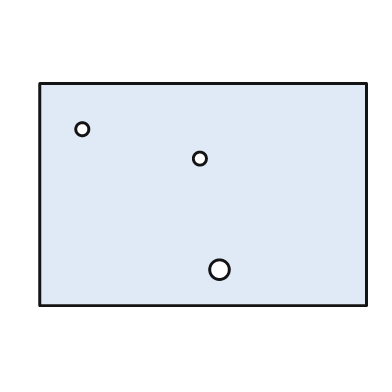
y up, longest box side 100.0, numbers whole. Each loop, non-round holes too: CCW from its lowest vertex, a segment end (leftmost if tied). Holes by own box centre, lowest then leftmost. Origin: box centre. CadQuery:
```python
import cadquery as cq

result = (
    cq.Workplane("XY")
    .moveTo(-50.0, -34.0)
    .lineTo(50.0, -34.0)
    .lineTo(50.0, 34.0)
    .lineTo(-50.0, 34.0)
    .close()
    .moveTo(5.0, -23.0)
    .circle(3.0)
    .moveTo(-1.0, 11.0)
    .circle(2.0)
    .moveTo(-37.0, 20.0)
    .circle(2.0)
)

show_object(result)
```